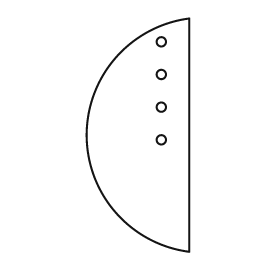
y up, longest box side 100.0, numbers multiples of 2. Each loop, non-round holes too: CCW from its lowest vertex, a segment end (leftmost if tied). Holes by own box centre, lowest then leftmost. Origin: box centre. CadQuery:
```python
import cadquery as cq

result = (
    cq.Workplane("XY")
    .moveTo(22.0, -50.0)
    .lineTo(22.0, 50.0)
    .threePointArc((-22.0, 0.0), (22.0, -50.0))
    .close()
    .moveTo(10.0, -2.0)
    .circle(2.0)
    .moveTo(10.0, 12.0)
    .circle(2.0)
    .moveTo(10.0, 26.0)
    .circle(2.0)
    .moveTo(10.0, 40.0)
    .circle(2.0)
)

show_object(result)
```